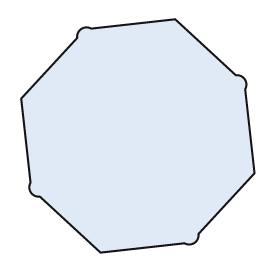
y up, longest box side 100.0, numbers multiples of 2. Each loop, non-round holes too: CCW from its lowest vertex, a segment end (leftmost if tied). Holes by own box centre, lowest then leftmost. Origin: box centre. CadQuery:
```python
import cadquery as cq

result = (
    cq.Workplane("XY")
    .moveTo(-16.0, -50.0)
    .lineTo(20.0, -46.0)
    .threePointArc((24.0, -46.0), (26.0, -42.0))
    .lineTo(50.0, -16.0)
    .lineTo(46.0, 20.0)
    .threePointArc((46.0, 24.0), (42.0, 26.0))
    .lineTo(16.0, 50.0)
    .lineTo(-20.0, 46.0)
    .threePointArc((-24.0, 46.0), (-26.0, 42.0))
    .lineTo(-50.0, 16.0)
    .lineTo(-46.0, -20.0)
    .threePointArc((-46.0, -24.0), (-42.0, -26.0))
    .close()
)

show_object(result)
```